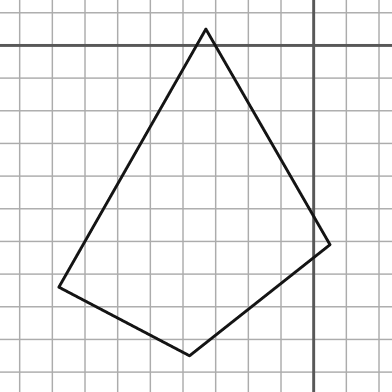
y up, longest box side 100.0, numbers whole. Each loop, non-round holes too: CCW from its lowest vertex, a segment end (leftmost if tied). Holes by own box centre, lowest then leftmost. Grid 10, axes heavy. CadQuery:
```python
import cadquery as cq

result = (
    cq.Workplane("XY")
    .moveTo(-38.0, -95.0)
    .lineTo(5.0, -61.0)
    .lineTo(-33.0, 5.0)
    .lineTo(-78.0, -74.0)
    .close()
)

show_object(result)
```